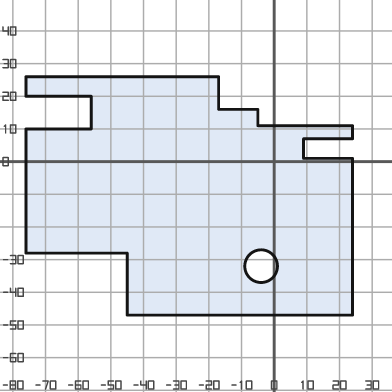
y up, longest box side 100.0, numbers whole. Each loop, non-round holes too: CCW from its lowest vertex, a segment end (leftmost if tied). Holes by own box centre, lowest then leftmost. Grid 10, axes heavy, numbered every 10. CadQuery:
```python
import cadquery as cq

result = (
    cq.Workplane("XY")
    .moveTo(-45.0, -47.0)
    .lineTo(24.0, -47.0)
    .lineTo(24.0, 1.0)
    .lineTo(9.0, 1.0)
    .lineTo(9.0, 7.0)
    .lineTo(24.0, 7.0)
    .lineTo(24.0, 11.0)
    .lineTo(-5.0, 11.0)
    .lineTo(-5.0, 16.0)
    .lineTo(-17.0, 16.0)
    .lineTo(-17.0, 26.0)
    .lineTo(-76.0, 26.0)
    .lineTo(-76.0, 20.0)
    .lineTo(-56.0, 20.0)
    .lineTo(-56.0, 10.0)
    .lineTo(-76.0, 10.0)
    .lineTo(-76.0, -28.0)
    .lineTo(-45.0, -28.0)
    .close()
    .moveTo(-4.0, -32.0)
    .circle(5.0)
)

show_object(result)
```